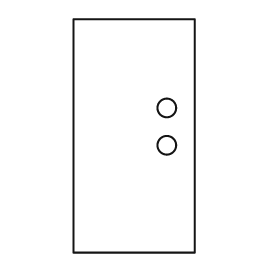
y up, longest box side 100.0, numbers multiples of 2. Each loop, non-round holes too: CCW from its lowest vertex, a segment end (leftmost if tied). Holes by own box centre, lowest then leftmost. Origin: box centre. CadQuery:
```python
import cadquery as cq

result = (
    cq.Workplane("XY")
    .moveTo(-26.0, -50.0)
    .lineTo(26.0, -50.0)
    .lineTo(26.0, 50.0)
    .lineTo(-26.0, 50.0)
    .close()
    .moveTo(14.0, -4.0)
    .circle(4.0)
    .moveTo(14.0, 12.0)
    .circle(4.0)
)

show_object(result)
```